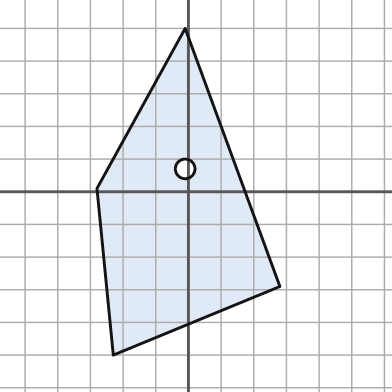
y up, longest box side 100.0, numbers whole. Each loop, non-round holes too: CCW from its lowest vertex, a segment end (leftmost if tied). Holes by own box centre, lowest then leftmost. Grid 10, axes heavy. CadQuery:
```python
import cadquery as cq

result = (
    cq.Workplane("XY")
    .moveTo(-23.0, -50.0)
    .lineTo(28.0, -29.0)
    .lineTo(-1.0, 50.0)
    .lineTo(-28.0, 1.0)
    .close()
    .moveTo(-1.0, 7.0)
    .circle(3.0)
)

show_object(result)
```